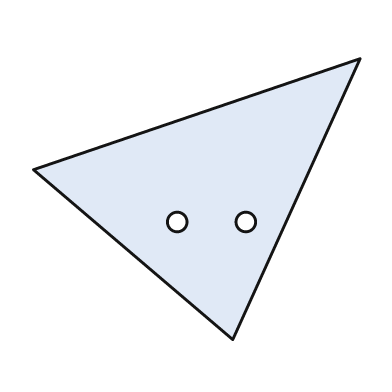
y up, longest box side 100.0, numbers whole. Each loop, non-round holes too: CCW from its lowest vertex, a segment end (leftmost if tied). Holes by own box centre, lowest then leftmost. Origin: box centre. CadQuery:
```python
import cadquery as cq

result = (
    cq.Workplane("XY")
    .moveTo(11.0, -43.0)
    .lineTo(50.0, 43.0)
    .lineTo(-50.0, 9.0)
    .close()
    .moveTo(-6.0, -7.0)
    .circle(3.0)
    .moveTo(15.0, -7.0)
    .circle(3.0)
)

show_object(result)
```